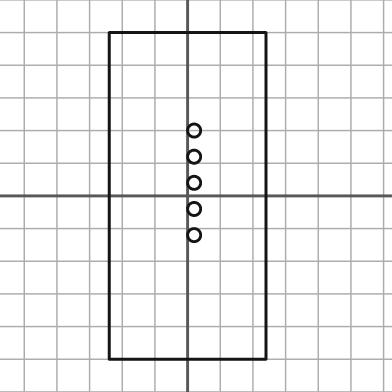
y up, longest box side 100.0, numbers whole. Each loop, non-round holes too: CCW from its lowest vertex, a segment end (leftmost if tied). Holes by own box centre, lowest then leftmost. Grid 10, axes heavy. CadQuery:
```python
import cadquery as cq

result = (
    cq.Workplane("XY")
    .moveTo(-24.0, -50.0)
    .lineTo(24.0, -50.0)
    .lineTo(24.0, 50.0)
    .lineTo(-24.0, 50.0)
    .close()
    .moveTo(2.0, -12.0)
    .circle(2.0)
    .moveTo(2.0, -4.0)
    .circle(2.0)
    .moveTo(2.0, 4.0)
    .circle(2.0)
    .moveTo(2.0, 12.0)
    .circle(2.0)
    .moveTo(2.0, 20.0)
    .circle(2.0)
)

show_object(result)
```